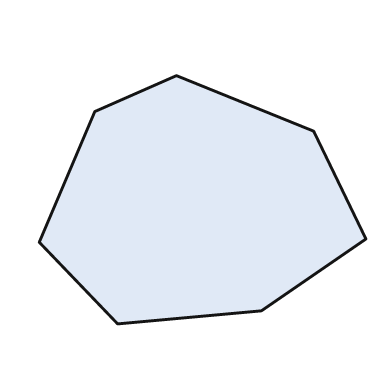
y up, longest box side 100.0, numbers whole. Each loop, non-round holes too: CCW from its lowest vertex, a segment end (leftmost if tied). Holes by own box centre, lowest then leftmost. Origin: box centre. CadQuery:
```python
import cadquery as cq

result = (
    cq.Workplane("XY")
    .moveTo(-26.0, -38.0)
    .lineTo(18.0, -34.0)
    .lineTo(50.0, -12.0)
    .lineTo(34.0, 21.0)
    .lineTo(-8.0, 38.0)
    .lineTo(-33.0, 27.0)
    .lineTo(-50.0, -13.0)
    .close()
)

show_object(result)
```